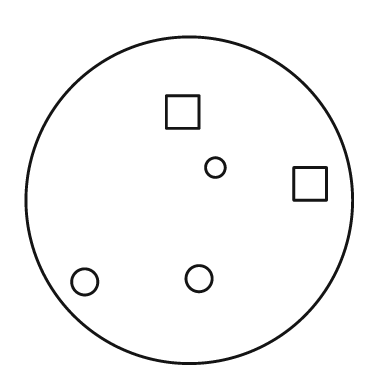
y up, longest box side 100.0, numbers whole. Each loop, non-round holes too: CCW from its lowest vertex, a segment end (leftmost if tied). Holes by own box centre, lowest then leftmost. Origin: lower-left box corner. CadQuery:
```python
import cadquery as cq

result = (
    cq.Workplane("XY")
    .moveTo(50.0, 50.0)
    .circle(50.0)
    .moveTo(18.0, 25.0)
    .circle(4.0)
    .moveTo(53.0, 26.0)
    .circle(4.0)
    .moveTo(82.0, 50.0)
    .lineTo(92.0, 50.0)
    .lineTo(92.0, 60.0)
    .lineTo(82.0, 60.0)
    .close()
    .moveTo(58.0, 60.0)
    .circle(3.0)
    .moveTo(43.0, 72.0)
    .lineTo(53.0, 72.0)
    .lineTo(53.0, 82.0)
    .lineTo(43.0, 82.0)
    .close()
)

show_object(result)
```